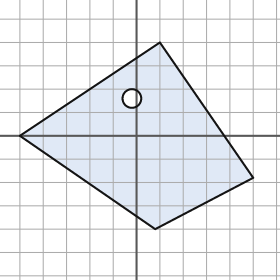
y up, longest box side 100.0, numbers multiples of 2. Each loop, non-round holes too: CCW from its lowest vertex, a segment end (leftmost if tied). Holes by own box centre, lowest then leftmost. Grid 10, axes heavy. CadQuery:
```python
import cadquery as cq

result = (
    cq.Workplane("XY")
    .moveTo(8.0, -40.0)
    .lineTo(50.0, -18.0)
    .lineTo(10.0, 40.0)
    .lineTo(-50.0, 0.0)
    .close()
    .moveTo(-2.0, 16.0)
    .circle(4.0)
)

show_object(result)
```